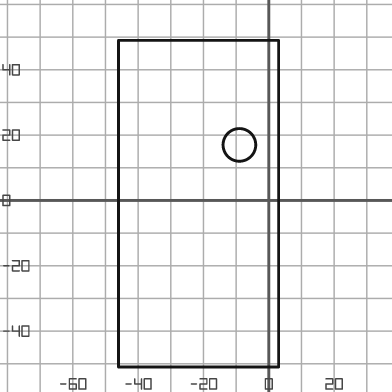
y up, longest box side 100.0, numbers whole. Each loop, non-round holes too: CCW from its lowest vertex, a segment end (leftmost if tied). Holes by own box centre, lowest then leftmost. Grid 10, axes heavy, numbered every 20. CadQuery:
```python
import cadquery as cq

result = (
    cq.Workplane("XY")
    .moveTo(-46.0, -51.0)
    .lineTo(3.0, -51.0)
    .lineTo(3.0, 49.0)
    .lineTo(-46.0, 49.0)
    .close()
    .moveTo(-9.0, 17.0)
    .circle(5.0)
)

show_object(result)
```